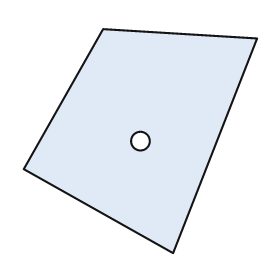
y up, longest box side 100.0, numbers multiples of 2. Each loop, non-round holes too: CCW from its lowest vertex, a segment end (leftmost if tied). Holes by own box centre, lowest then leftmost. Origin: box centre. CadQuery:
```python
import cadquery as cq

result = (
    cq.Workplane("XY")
    .moveTo(14.0, -48.0)
    .lineTo(50.0, 44.0)
    .lineTo(-16.0, 48.0)
    .lineTo(-50.0, -12.0)
    .close()
    .moveTo(0.0, 0.0)
    .circle(4.0)
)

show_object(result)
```